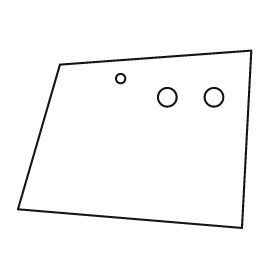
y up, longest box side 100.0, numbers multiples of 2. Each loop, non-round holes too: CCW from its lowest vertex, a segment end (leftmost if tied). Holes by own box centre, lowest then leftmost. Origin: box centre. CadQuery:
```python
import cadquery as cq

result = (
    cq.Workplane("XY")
    .moveTo(46.0, -38.0)
    .lineTo(50.0, 38.0)
    .lineTo(-32.0, 32.0)
    .lineTo(-50.0, -30.0)
    .close()
    .moveTo(14.0, 18.0)
    .circle(4.0)
    .moveTo(34.0, 18.0)
    .circle(4.0)
    .moveTo(-6.0, 26.0)
    .circle(2.0)
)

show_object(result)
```